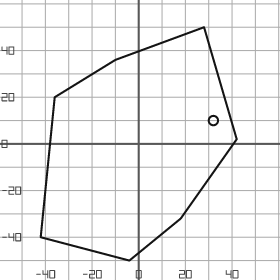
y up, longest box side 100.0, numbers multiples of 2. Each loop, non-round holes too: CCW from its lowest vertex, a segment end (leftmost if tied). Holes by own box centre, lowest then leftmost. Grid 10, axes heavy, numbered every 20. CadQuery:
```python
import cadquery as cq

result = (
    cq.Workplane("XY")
    .moveTo(-4.0, -50.0)
    .lineTo(18.0, -32.0)
    .lineTo(42.0, 2.0)
    .lineTo(28.0, 50.0)
    .lineTo(-10.0, 36.0)
    .lineTo(-36.0, 20.0)
    .lineTo(-42.0, -40.0)
    .close()
    .moveTo(32.0, 10.0)
    .circle(2.0)
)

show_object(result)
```